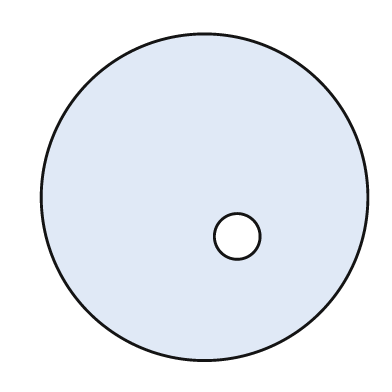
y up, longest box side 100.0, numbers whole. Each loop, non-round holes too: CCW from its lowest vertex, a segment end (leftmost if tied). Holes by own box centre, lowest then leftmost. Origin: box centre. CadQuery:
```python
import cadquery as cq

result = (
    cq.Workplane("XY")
    .moveTo(0.0, 0.0)
    .circle(50.0)
    .moveTo(10.0, -12.0)
    .circle(7.0)
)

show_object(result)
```